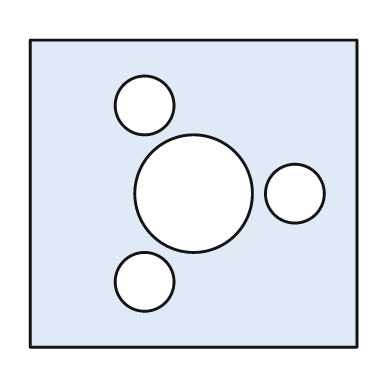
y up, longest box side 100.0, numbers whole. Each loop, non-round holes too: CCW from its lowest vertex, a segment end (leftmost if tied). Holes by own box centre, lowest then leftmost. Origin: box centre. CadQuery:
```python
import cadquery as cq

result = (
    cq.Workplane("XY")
    .moveTo(-50.0, -47.0)
    .lineTo(50.0, -47.0)
    .lineTo(50.0, 47.0)
    .lineTo(-50.0, 47.0)
    .close()
    .moveTo(-15.0, -27.0)
    .circle(9.0)
    .moveTo(0.0, 0.0)
    .circle(18.0)
    .moveTo(31.0, 0.0)
    .circle(9.0)
    .moveTo(-15.0, 27.0)
    .circle(9.0)
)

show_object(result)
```